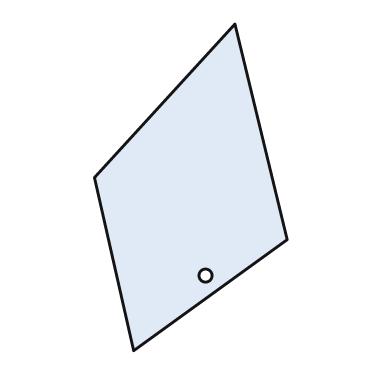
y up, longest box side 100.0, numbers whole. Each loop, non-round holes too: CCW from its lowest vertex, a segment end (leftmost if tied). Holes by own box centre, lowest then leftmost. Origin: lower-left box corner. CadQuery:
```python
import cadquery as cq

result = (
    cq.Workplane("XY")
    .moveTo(12.0, 0.0)
    .lineTo(59.0, 34.0)
    .lineTo(43.0, 100.0)
    .lineTo(0.0, 53.0)
    .close()
    .moveTo(34.0, 23.0)
    .circle(2.0)
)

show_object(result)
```